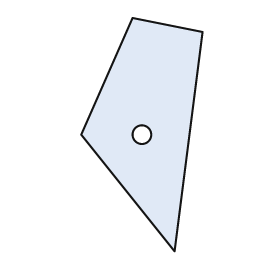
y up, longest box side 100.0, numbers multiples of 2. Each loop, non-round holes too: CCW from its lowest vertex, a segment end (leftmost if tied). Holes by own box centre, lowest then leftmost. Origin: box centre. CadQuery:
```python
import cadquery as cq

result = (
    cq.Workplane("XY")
    .moveTo(14.0, -50.0)
    .lineTo(26.0, 44.0)
    .lineTo(-4.0, 50.0)
    .lineTo(-26.0, 0.0)
    .close()
    .moveTo(0.0, 0.0)
    .circle(4.0)
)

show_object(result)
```